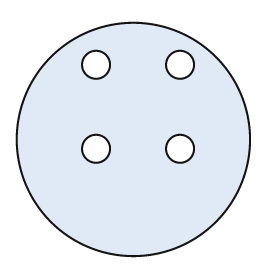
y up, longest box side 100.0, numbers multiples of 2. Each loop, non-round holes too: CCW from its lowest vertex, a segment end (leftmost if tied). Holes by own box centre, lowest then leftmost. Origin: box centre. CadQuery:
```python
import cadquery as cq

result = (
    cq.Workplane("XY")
    .moveTo(0.0, 0.0)
    .circle(50.0)
    .moveTo(-16.0, -4.0)
    .circle(6.0)
    .moveTo(20.0, -4.0)
    .circle(6.0)
    .moveTo(-16.0, 32.0)
    .circle(6.0)
    .moveTo(20.0, 32.0)
    .circle(6.0)
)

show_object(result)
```